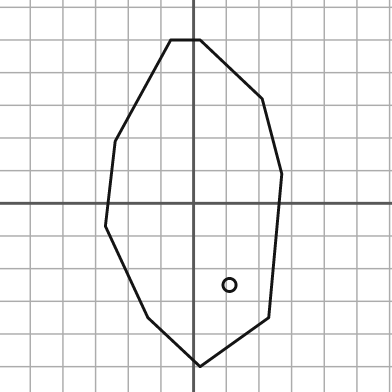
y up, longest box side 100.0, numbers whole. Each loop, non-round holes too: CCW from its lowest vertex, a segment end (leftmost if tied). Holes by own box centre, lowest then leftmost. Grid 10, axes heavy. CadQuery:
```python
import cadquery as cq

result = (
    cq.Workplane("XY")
    .moveTo(2.0, -50.0)
    .lineTo(23.0, -35.0)
    .lineTo(27.0, 9.0)
    .lineTo(21.0, 32.0)
    .lineTo(2.0, 50.0)
    .lineTo(-7.0, 50.0)
    .lineTo(-24.0, 19.0)
    .lineTo(-27.0, -7.0)
    .lineTo(-14.0, -35.0)
    .close()
    .moveTo(11.0, -25.0)
    .circle(2.0)
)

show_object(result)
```